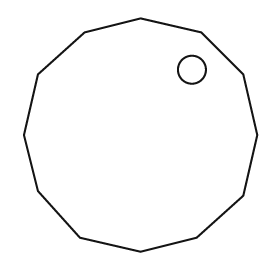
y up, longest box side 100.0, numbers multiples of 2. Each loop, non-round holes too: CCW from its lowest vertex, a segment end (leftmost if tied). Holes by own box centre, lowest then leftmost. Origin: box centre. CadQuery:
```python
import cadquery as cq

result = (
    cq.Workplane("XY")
    .moveTo(0.0, -50.0)
    .lineTo(24.0, -44.0)
    .lineTo(44.0, -26.0)
    .lineTo(50.0, 0.0)
    .lineTo(44.0, 26.0)
    .lineTo(26.0, 44.0)
    .lineTo(0.0, 50.0)
    .lineTo(-24.0, 44.0)
    .lineTo(-44.0, 26.0)
    .lineTo(-50.0, 0.0)
    .lineTo(-44.0, -24.0)
    .lineTo(-26.0, -44.0)
    .close()
    .moveTo(22.0, 28.0)
    .circle(6.0)
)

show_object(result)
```